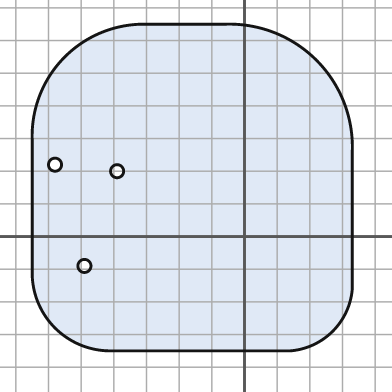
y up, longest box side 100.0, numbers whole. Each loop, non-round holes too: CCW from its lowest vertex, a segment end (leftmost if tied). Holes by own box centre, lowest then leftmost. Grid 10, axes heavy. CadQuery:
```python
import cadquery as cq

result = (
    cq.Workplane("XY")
    .moveTo(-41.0, -35.0)
    .lineTo(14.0, -35.0)
    .threePointArc((27.0, -29.0), (33.0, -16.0))
    .lineTo(33.0, 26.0)
    .threePointArc((22.0, 54.0), (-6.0, 65.0))
    .lineTo(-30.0, 65.0)
    .threePointArc((-55.0, 55.0), (-65.0, 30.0))
    .lineTo(-65.0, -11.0)
    .threePointArc((-58.0, -28.0), (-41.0, -35.0))
    .close()
    .moveTo(-49.0, -9.0)
    .circle(2.0)
    .moveTo(-39.0, 20.0)
    .circle(2.0)
    .moveTo(-58.0, 22.0)
    .circle(2.0)
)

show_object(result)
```